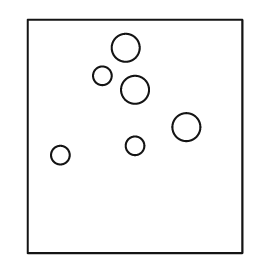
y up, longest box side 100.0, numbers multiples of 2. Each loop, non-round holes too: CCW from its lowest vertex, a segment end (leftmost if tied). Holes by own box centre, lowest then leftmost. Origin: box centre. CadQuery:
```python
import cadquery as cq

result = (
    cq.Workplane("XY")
    .moveTo(-46.0, -50.0)
    .lineTo(46.0, -50.0)
    .lineTo(46.0, 50.0)
    .lineTo(-46.0, 50.0)
    .close()
    .moveTo(-32.0, -8.0)
    .circle(4.0)
    .moveTo(0.0, -4.0)
    .circle(4.0)
    .moveTo(22.0, 4.0)
    .circle(6.0)
    .moveTo(0.0, 20.0)
    .circle(6.0)
    .moveTo(-14.0, 26.0)
    .circle(4.0)
    .moveTo(-4.0, 38.0)
    .circle(6.0)
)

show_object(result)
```